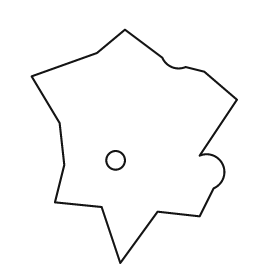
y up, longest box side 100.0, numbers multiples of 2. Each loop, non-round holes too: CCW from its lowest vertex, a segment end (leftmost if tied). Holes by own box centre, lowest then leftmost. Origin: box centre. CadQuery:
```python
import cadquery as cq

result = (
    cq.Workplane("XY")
    .moveTo(-6.0, -50.0)
    .lineTo(10.0, -28.0)
    .lineTo(28.0, -30.0)
    .lineTo(34.0, -18.0)
    .threePointArc((38.0, -8.0), (28.0, -4.0))
    .lineTo(44.0, 20.0)
    .lineTo(30.0, 32.0)
    .lineTo(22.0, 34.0)
    .threePointArc((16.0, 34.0), (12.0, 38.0))
    .lineTo(-4.0, 50.0)
    .lineTo(-16.0, 40.0)
    .lineTo(-44.0, 30.0)
    .lineTo(-32.0, 10.0)
    .lineTo(-30.0, -8.0)
    .lineTo(-34.0, -24.0)
    .lineTo(-14.0, -26.0)
    .close()
    .moveTo(-8.0, -6.0)
    .circle(4.0)
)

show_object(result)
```